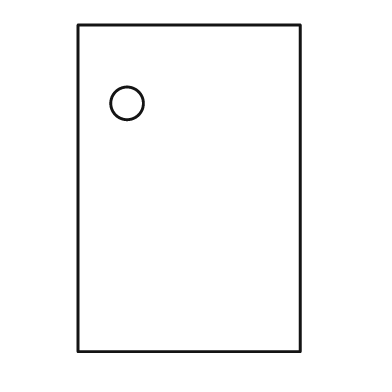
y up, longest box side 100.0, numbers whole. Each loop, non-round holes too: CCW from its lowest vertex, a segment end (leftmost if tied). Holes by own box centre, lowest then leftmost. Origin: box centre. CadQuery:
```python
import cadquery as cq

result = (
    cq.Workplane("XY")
    .moveTo(-34.0, -50.0)
    .lineTo(34.0, -50.0)
    .lineTo(34.0, 50.0)
    .lineTo(-34.0, 50.0)
    .close()
    .moveTo(-19.0, 26.0)
    .circle(5.0)
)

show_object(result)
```